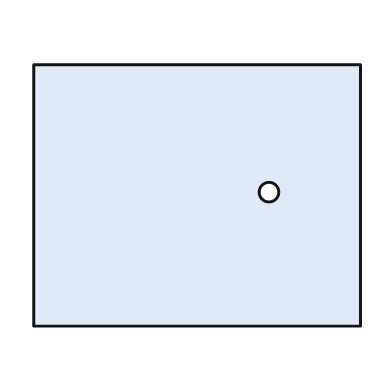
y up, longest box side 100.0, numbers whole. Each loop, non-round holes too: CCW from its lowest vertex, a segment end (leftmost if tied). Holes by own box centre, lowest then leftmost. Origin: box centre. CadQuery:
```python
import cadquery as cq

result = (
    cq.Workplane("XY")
    .moveTo(-50.0, -40.0)
    .lineTo(50.0, -40.0)
    .lineTo(50.0, 40.0)
    .lineTo(-50.0, 40.0)
    .close()
    .moveTo(22.0, 1.0)
    .circle(3.0)
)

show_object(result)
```